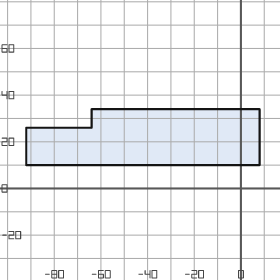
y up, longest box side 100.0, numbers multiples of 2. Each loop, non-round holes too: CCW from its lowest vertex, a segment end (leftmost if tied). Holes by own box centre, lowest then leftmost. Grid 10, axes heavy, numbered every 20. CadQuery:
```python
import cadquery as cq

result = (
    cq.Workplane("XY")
    .moveTo(-92.0, 10.0)
    .lineTo(8.0, 10.0)
    .lineTo(8.0, 34.0)
    .lineTo(-64.0, 34.0)
    .lineTo(-64.0, 26.0)
    .lineTo(-92.0, 26.0)
    .close()
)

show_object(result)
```